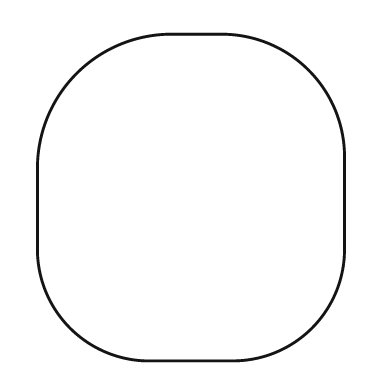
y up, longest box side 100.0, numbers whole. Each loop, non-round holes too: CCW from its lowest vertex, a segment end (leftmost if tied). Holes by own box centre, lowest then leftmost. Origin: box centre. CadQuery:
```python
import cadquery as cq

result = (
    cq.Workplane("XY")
    .moveTo(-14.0, -50.0)
    .lineTo(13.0, -50.0)
    .threePointArc((37.0, -40.0), (47.0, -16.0))
    .lineTo(47.0, 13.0)
    .threePointArc((36.0, 39.0), (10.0, 50.0))
    .lineTo(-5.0, 50.0)
    .threePointArc((-35.0, 38.0), (-47.0, 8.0))
    .lineTo(-47.0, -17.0)
    .threePointArc((-37.0, -40.0), (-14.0, -50.0))
    .close()
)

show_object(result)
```